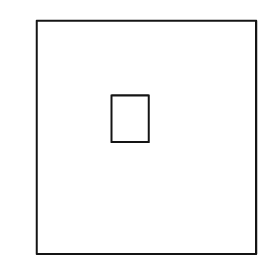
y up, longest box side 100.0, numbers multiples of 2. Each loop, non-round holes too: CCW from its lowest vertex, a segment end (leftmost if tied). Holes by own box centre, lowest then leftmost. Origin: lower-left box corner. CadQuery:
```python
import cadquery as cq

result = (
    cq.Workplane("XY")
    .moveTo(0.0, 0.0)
    .lineTo(94.0, 0.0)
    .lineTo(94.0, 100.0)
    .lineTo(0.0, 100.0)
    .close()
    .moveTo(32.0, 48.0)
    .lineTo(48.0, 48.0)
    .lineTo(48.0, 68.0)
    .lineTo(32.0, 68.0)
    .close()
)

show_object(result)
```